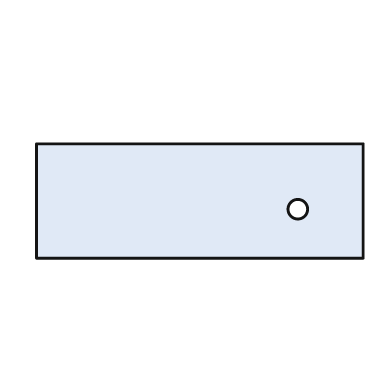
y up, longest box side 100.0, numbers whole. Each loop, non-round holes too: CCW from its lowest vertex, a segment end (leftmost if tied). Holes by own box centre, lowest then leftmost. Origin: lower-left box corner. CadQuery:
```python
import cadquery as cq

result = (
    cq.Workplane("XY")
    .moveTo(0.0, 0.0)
    .lineTo(100.0, 0.0)
    .lineTo(100.0, 35.0)
    .lineTo(0.0, 35.0)
    .close()
    .moveTo(80.0, 15.0)
    .circle(3.0)
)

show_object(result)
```